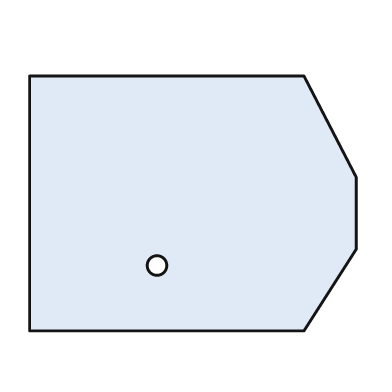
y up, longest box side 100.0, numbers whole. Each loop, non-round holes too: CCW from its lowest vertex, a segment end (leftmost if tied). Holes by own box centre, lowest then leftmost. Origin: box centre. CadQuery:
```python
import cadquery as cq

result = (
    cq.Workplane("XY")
    .moveTo(-50.0, -39.0)
    .lineTo(34.0, -39.0)
    .lineTo(50.0, -14.0)
    .lineTo(50.0, 8.0)
    .lineTo(34.0, 39.0)
    .lineTo(-50.0, 39.0)
    .close()
    .moveTo(-11.0, -19.0)
    .circle(3.0)
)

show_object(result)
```